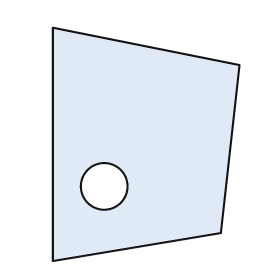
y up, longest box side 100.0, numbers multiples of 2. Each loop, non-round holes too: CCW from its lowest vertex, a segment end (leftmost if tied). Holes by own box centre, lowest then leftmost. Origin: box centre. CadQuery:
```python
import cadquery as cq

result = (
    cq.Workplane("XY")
    .moveTo(-40.0, -50.0)
    .lineTo(32.0, -38.0)
    .lineTo(40.0, 34.0)
    .lineTo(-40.0, 50.0)
    .close()
    .moveTo(-18.0, -18.0)
    .circle(10.0)
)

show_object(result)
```